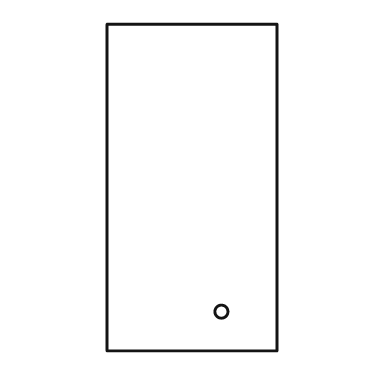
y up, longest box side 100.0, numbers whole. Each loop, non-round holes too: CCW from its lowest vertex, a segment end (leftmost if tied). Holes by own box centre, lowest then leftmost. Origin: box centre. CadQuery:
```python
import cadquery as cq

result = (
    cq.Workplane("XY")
    .moveTo(-26.0, -50.0)
    .lineTo(26.0, -50.0)
    .lineTo(26.0, 50.0)
    .lineTo(-26.0, 50.0)
    .close()
    .moveTo(9.0, -38.0)
    .circle(2.0)
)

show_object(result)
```